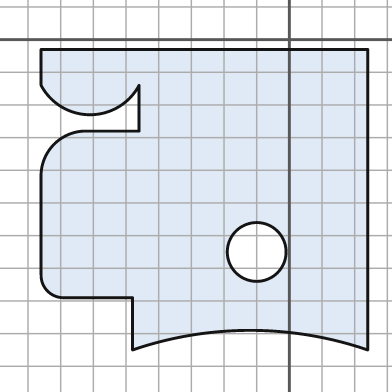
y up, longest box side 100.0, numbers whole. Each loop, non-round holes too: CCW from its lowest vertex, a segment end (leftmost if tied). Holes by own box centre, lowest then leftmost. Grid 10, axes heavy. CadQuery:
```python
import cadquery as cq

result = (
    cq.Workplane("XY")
    .moveTo(-48.0, -95.0)
    .threePointArc((-12.0, -89.0), (24.0, -95.0))
    .lineTo(24.0, -3.0)
    .lineTo(-76.0, -3.0)
    .lineTo(-76.0, -14.0)
    .threePointArc((-61.0, -23.0), (-46.0, -14.0))
    .lineTo(-46.0, -28.0)
    .lineTo(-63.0, -28.0)
    .threePointArc((-72.0, -32.0), (-76.0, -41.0))
    .lineTo(-76.0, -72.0)
    .threePointArc((-74.0, -77.0), (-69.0, -79.0))
    .lineTo(-48.0, -79.0)
    .close()
    .moveTo(-10.0, -65.0)
    .circle(9.0)
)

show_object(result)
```